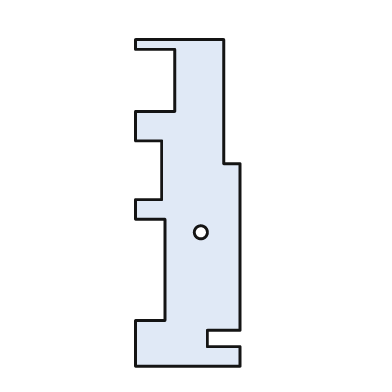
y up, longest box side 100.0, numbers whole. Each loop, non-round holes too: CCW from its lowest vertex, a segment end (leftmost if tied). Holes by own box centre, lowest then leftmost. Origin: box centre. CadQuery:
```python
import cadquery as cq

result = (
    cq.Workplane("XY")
    .moveTo(-16.0, -50.0)
    .lineTo(16.0, -50.0)
    .lineTo(16.0, -44.0)
    .lineTo(6.0, -44.0)
    .lineTo(6.0, -39.0)
    .lineTo(16.0, -39.0)
    .lineTo(16.0, 12.0)
    .lineTo(11.0, 12.0)
    .lineTo(11.0, 50.0)
    .lineTo(-16.0, 50.0)
    .lineTo(-16.0, 47.0)
    .lineTo(-4.0, 47.0)
    .lineTo(-4.0, 28.0)
    .lineTo(-16.0, 28.0)
    .lineTo(-16.0, 19.0)
    .lineTo(-8.0, 19.0)
    .lineTo(-8.0, 1.0)
    .lineTo(-16.0, 1.0)
    .lineTo(-16.0, -5.0)
    .lineTo(-7.0, -5.0)
    .lineTo(-7.0, -36.0)
    .lineTo(-16.0, -36.0)
    .close()
    .moveTo(4.0, -9.0)
    .circle(2.0)
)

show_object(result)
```